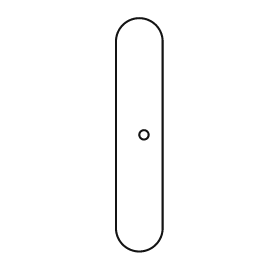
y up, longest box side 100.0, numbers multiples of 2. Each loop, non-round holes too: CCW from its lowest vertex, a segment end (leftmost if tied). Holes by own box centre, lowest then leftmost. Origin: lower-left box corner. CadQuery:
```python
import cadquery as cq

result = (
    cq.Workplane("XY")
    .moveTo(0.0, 10.0)
    .threePointArc((10.0, 0.0), (20.0, 10.0))
    .lineTo(20.0, 90.0)
    .threePointArc((10.0, 100.0), (0.0, 90.0))
    .close()
    .moveTo(12.0, 50.0)
    .circle(2.0)
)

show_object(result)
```